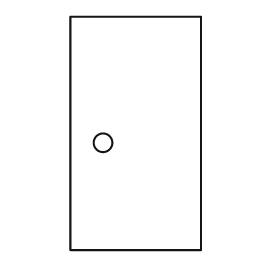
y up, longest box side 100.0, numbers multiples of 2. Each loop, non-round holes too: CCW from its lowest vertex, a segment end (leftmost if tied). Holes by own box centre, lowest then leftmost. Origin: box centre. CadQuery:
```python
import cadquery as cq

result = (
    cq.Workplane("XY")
    .moveTo(-28.0, -50.0)
    .lineTo(28.0, -50.0)
    .lineTo(28.0, 50.0)
    .lineTo(-28.0, 50.0)
    .close()
    .moveTo(-14.0, -4.0)
    .circle(4.0)
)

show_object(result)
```